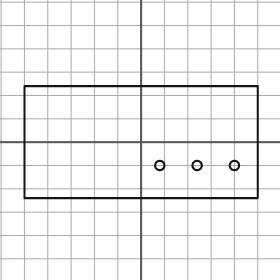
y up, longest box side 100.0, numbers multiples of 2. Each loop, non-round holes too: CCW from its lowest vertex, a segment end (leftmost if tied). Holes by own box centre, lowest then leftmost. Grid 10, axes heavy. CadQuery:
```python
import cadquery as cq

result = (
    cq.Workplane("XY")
    .moveTo(-50.0, -24.0)
    .lineTo(50.0, -24.0)
    .lineTo(50.0, 24.0)
    .lineTo(-50.0, 24.0)
    .close()
    .moveTo(8.0, -10.0)
    .circle(2.0)
    .moveTo(24.0, -10.0)
    .circle(2.0)
    .moveTo(40.0, -10.0)
    .circle(2.0)
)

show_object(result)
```